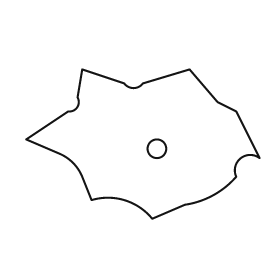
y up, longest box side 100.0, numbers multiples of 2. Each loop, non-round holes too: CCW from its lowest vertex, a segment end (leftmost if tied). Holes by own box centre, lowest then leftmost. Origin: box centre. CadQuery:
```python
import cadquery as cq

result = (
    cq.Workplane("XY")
    .moveTo(4.0, -32.0)
    .lineTo(18.0, -26.0)
    .threePointArc((30.0, -22.0), (40.0, -14.0))
    .threePointArc((42.0, -6.0), (50.0, -6.0))
    .lineTo(40.0, 14.0)
    .lineTo(32.0, 18.0)
    .lineTo(20.0, 32.0)
    .lineTo(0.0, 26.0)
    .threePointArc((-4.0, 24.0), (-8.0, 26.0))
    .lineTo(-26.0, 32.0)
    .lineTo(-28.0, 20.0)
    .threePointArc((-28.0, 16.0), (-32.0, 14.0))
    .lineTo(-50.0, 2.0)
    .lineTo(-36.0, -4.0)
    .threePointArc((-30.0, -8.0), (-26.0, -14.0))
    .lineTo(-22.0, -24.0)
    .threePointArc((-8.0, -24.0), (4.0, -32.0))
    .close()
    .moveTo(6.0, -2.0)
    .circle(4.0)
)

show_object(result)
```